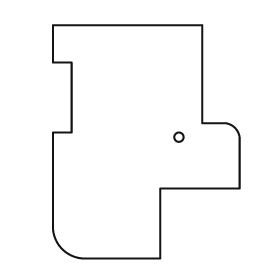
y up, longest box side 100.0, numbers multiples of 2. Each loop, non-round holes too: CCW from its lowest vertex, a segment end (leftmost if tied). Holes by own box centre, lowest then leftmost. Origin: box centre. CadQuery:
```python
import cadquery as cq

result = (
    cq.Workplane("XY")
    .moveTo(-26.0, -50.0)
    .lineTo(6.0, -50.0)
    .lineTo(6.0, -20.0)
    .lineTo(40.0, -20.0)
    .lineTo(40.0, 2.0)
    .threePointArc((38.0, 6.0), (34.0, 8.0))
    .lineTo(24.0, 8.0)
    .lineTo(24.0, 50.0)
    .lineTo(-40.0, 50.0)
    .lineTo(-40.0, 34.0)
    .lineTo(-32.0, 34.0)
    .lineTo(-32.0, 4.0)
    .lineTo(-40.0, 4.0)
    .lineTo(-40.0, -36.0)
    .threePointArc((-36.0, -46.0), (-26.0, -50.0))
    .close()
    .moveTo(14.0, 2.0)
    .circle(2.0)
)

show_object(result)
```